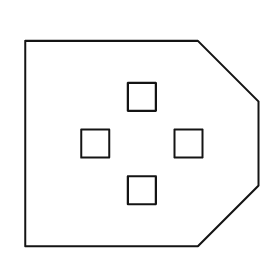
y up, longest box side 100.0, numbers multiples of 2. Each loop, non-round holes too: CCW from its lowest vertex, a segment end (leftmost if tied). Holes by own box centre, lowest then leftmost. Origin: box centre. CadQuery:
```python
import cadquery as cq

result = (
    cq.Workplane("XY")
    .moveTo(-50.0, -44.0)
    .lineTo(24.0, -44.0)
    .lineTo(50.0, -18.0)
    .lineTo(50.0, 18.0)
    .lineTo(24.0, 44.0)
    .lineTo(-50.0, 44.0)
    .close()
    .moveTo(-6.0, -26.0)
    .lineTo(6.0, -26.0)
    .lineTo(6.0, -14.0)
    .lineTo(-6.0, -14.0)
    .close()
    .moveTo(-26.0, -6.0)
    .lineTo(-14.0, -6.0)
    .lineTo(-14.0, 6.0)
    .lineTo(-26.0, 6.0)
    .close()
    .moveTo(14.0, -6.0)
    .lineTo(26.0, -6.0)
    .lineTo(26.0, 6.0)
    .lineTo(14.0, 6.0)
    .close()
    .moveTo(-6.0, 14.0)
    .lineTo(6.0, 14.0)
    .lineTo(6.0, 26.0)
    .lineTo(-6.0, 26.0)
    .close()
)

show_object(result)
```